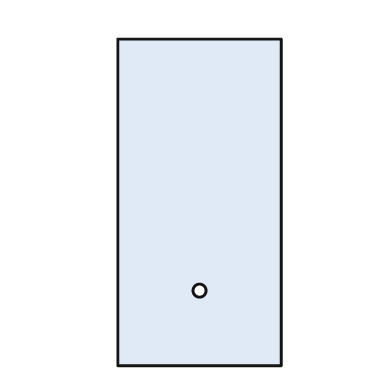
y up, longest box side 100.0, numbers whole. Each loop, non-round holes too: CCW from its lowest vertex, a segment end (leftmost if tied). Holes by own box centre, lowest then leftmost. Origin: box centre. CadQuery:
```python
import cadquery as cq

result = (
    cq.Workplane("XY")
    .moveTo(-25.0, -50.0)
    .lineTo(25.0, -50.0)
    .lineTo(25.0, 50.0)
    .lineTo(-25.0, 50.0)
    .close()
    .moveTo(0.0, -27.0)
    .circle(2.0)
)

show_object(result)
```